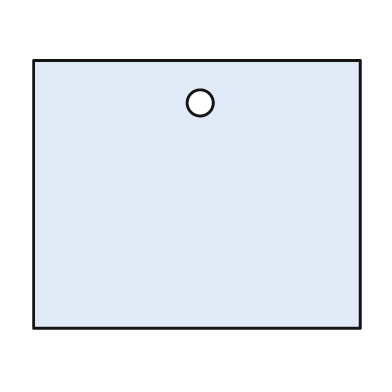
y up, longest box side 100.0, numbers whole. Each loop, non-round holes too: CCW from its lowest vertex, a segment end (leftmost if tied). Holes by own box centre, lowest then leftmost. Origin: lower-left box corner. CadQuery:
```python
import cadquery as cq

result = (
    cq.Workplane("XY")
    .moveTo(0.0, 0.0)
    .lineTo(100.0, 0.0)
    .lineTo(100.0, 82.0)
    .lineTo(0.0, 82.0)
    .close()
    .moveTo(51.0, 69.0)
    .circle(4.0)
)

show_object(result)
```